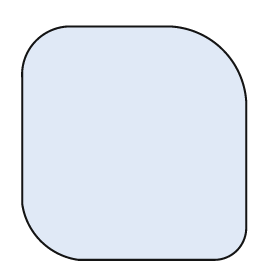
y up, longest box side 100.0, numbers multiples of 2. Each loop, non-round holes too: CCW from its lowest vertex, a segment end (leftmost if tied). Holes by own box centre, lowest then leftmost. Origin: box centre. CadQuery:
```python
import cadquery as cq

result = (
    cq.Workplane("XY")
    .moveTo(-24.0, -50.0)
    .lineTo(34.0, -50.0)
    .threePointArc((44.0, -46.0), (48.0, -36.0))
    .lineTo(48.0, 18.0)
    .threePointArc((38.0, 40.0), (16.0, 50.0))
    .lineTo(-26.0, 50.0)
    .threePointArc((-42.0, 44.0), (-48.0, 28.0))
    .lineTo(-48.0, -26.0)
    .threePointArc((-40.0, -42.0), (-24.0, -50.0))
    .close()
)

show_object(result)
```